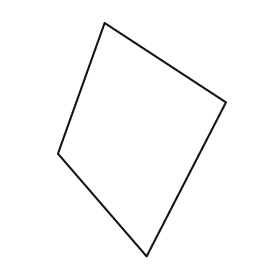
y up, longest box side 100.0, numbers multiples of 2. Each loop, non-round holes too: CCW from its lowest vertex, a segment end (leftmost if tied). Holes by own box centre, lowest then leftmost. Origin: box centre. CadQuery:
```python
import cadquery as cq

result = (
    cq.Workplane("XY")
    .moveTo(2.0, -50.0)
    .lineTo(36.0, 16.0)
    .lineTo(-16.0, 50.0)
    .lineTo(-36.0, -6.0)
    .close()
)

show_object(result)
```